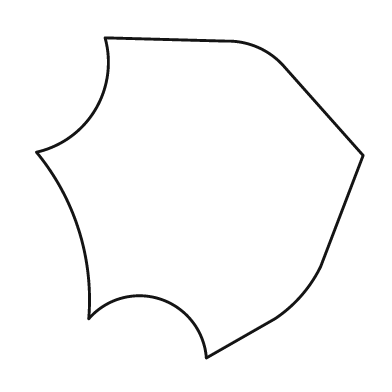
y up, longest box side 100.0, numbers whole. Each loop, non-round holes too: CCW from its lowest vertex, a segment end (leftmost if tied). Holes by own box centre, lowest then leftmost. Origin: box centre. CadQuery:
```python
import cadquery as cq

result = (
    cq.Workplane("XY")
    .moveTo(2.0, -49.0)
    .lineTo(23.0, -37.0)
    .threePointArc((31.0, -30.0), (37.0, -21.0))
    .lineTo(50.0, 13.0)
    .lineTo(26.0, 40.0)
    .threePointArc((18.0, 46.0), (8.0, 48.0))
    .lineTo(-29.0, 49.0)
    .threePointArc((-32.0, 27.0), (-50.0, 14.0))
    .threePointArc((-37.0, -10.0), (-34.0, -37.0))
    .threePointArc((-12.0, -31.0), (2.0, -49.0))
    .close()
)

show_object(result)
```